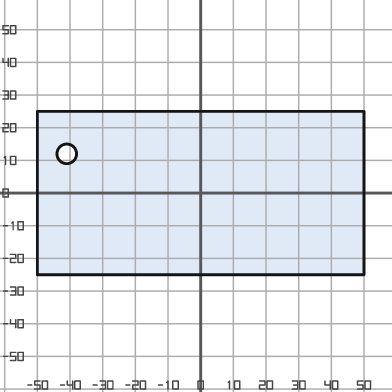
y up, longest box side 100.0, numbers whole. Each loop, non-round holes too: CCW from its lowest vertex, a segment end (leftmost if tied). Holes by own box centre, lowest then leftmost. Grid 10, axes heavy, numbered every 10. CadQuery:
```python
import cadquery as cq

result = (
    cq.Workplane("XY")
    .moveTo(-50.0, -25.0)
    .lineTo(50.0, -25.0)
    .lineTo(50.0, 25.0)
    .lineTo(-50.0, 25.0)
    .close()
    .moveTo(-41.0, 12.0)
    .circle(3.0)
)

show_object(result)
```